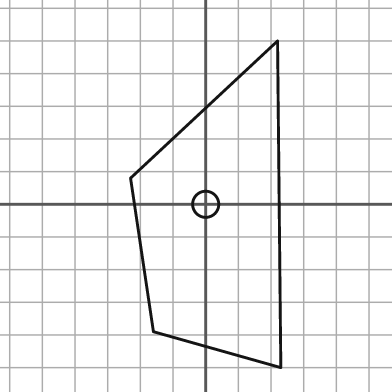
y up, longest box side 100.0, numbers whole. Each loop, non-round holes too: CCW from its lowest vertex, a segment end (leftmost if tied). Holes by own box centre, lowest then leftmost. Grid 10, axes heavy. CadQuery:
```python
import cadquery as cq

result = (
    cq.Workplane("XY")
    .moveTo(23.0, -50.0)
    .lineTo(22.0, 50.0)
    .lineTo(-23.0, 8.0)
    .lineTo(-16.0, -39.0)
    .close()
    .moveTo(0.0, 0.0)
    .circle(4.0)
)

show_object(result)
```